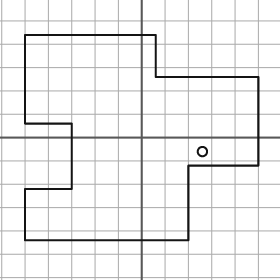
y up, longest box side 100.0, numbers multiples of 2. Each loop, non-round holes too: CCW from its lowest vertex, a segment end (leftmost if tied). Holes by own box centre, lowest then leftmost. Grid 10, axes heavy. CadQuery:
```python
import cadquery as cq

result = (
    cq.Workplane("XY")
    .moveTo(-50.0, -44.0)
    .lineTo(20.0, -44.0)
    .lineTo(20.0, -12.0)
    .lineTo(50.0, -12.0)
    .lineTo(50.0, 26.0)
    .lineTo(6.0, 26.0)
    .lineTo(6.0, 44.0)
    .lineTo(-50.0, 44.0)
    .lineTo(-50.0, 6.0)
    .lineTo(-30.0, 6.0)
    .lineTo(-30.0, -22.0)
    .lineTo(-50.0, -22.0)
    .close()
    .moveTo(26.0, -6.0)
    .circle(2.0)
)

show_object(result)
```